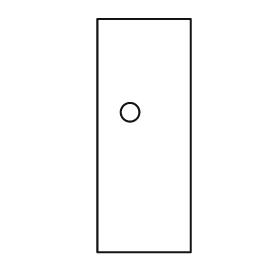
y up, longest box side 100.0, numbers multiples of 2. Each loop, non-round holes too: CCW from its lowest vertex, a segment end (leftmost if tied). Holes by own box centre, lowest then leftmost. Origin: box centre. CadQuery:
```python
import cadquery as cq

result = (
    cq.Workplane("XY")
    .moveTo(-20.0, -50.0)
    .lineTo(20.0, -50.0)
    .lineTo(20.0, 50.0)
    .lineTo(-20.0, 50.0)
    .close()
    .moveTo(-6.0, 10.0)
    .circle(4.0)
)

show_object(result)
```